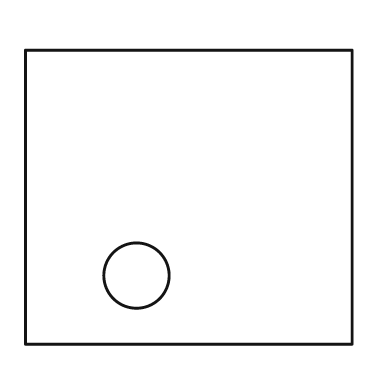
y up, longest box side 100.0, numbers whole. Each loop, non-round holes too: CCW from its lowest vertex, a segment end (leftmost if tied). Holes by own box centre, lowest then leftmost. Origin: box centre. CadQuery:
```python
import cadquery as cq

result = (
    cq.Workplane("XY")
    .moveTo(-50.0, -45.0)
    .lineTo(50.0, -45.0)
    .lineTo(50.0, 45.0)
    .lineTo(-50.0, 45.0)
    .close()
    .moveTo(-16.0, -24.0)
    .circle(10.0)
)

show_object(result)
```